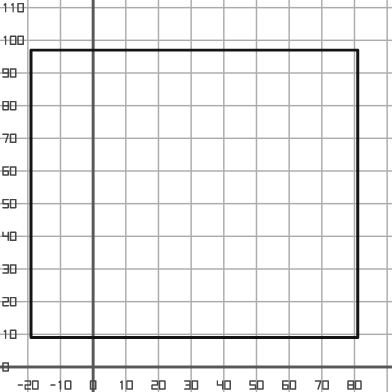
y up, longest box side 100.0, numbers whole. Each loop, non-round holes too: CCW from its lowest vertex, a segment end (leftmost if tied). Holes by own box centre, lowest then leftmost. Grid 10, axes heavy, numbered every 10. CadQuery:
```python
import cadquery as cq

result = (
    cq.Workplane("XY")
    .moveTo(-19.0, 9.0)
    .lineTo(81.0, 9.0)
    .lineTo(81.0, 97.0)
    .lineTo(-19.0, 97.0)
    .close()
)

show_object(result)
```